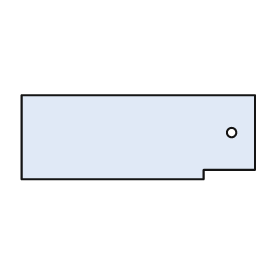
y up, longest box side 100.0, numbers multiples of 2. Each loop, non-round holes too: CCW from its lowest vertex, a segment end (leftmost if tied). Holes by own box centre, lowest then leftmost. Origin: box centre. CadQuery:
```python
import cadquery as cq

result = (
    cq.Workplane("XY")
    .moveTo(-50.0, -18.0)
    .lineTo(28.0, -18.0)
    .lineTo(28.0, -14.0)
    .lineTo(50.0, -14.0)
    .lineTo(50.0, 18.0)
    .lineTo(-50.0, 18.0)
    .close()
    .moveTo(40.0, 2.0)
    .circle(2.0)
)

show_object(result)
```